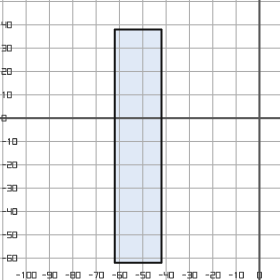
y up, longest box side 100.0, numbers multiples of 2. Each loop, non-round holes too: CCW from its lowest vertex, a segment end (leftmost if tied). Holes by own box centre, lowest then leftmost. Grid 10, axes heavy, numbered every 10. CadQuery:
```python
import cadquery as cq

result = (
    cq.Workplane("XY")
    .moveTo(-62.0, -62.0)
    .lineTo(-42.0, -62.0)
    .lineTo(-42.0, 38.0)
    .lineTo(-62.0, 38.0)
    .close()
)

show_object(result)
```